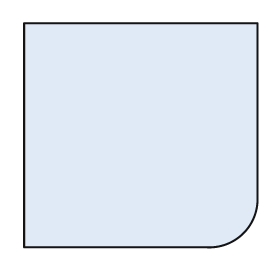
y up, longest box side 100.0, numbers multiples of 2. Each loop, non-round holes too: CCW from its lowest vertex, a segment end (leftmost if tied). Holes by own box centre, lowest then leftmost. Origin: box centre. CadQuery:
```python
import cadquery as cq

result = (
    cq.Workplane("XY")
    .moveTo(-50.0, -48.0)
    .lineTo(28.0, -48.0)
    .threePointArc((44.0, -42.0), (50.0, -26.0))
    .lineTo(50.0, 48.0)
    .lineTo(-50.0, 48.0)
    .close()
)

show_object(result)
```